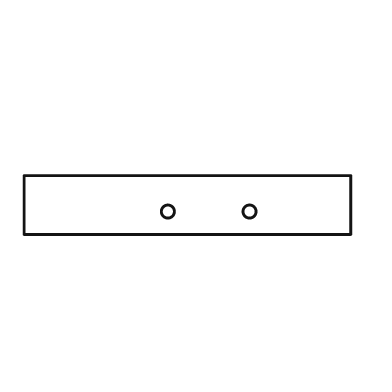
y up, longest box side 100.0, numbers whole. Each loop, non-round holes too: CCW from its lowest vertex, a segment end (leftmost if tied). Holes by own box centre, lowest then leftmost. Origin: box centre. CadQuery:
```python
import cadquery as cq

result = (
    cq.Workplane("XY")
    .moveTo(-50.0, -9.0)
    .lineTo(50.0, -9.0)
    .lineTo(50.0, 9.0)
    .lineTo(-50.0, 9.0)
    .close()
    .moveTo(-6.0, -2.0)
    .circle(2.0)
    .moveTo(19.0, -2.0)
    .circle(2.0)
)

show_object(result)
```